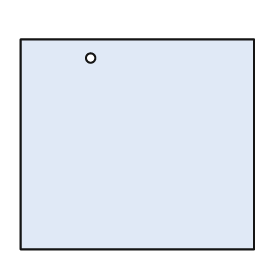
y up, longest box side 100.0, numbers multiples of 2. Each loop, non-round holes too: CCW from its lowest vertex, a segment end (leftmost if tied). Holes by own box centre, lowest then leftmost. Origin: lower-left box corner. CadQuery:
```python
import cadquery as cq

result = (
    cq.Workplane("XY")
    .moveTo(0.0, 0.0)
    .lineTo(100.0, 0.0)
    .lineTo(100.0, 90.0)
    .lineTo(0.0, 90.0)
    .close()
    .moveTo(30.0, 82.0)
    .circle(2.0)
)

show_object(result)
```